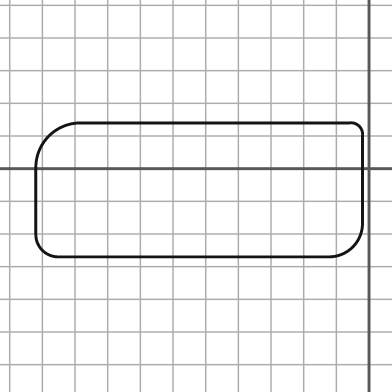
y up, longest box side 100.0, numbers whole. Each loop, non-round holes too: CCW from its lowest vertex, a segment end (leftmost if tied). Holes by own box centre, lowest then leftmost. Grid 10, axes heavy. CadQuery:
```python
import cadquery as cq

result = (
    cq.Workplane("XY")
    .moveTo(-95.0, -27.0)
    .lineTo(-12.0, -27.0)
    .threePointArc((-5.0, -24.0), (-2.0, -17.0))
    .lineTo(-2.0, 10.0)
    .threePointArc((-3.0, 13.0), (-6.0, 14.0))
    .lineTo(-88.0, 14.0)
    .threePointArc((-98.0, 10.0), (-102.0, 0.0))
    .lineTo(-102.0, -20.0)
    .threePointArc((-100.0, -25.0), (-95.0, -27.0))
    .close()
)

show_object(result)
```